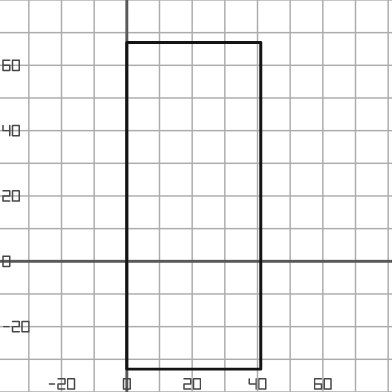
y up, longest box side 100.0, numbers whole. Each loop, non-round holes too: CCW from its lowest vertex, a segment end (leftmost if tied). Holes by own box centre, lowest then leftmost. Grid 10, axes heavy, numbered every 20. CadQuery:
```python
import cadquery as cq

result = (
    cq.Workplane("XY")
    .moveTo(0.0, -33.0)
    .lineTo(41.0, -33.0)
    .lineTo(41.0, 67.0)
    .lineTo(0.0, 67.0)
    .close()
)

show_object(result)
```